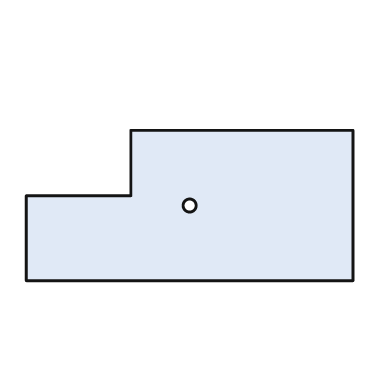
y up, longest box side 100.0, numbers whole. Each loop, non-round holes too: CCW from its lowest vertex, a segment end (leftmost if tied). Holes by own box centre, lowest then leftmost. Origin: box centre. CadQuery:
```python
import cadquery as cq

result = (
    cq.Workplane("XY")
    .moveTo(-50.0, -23.0)
    .lineTo(50.0, -23.0)
    .lineTo(50.0, 23.0)
    .lineTo(-18.0, 23.0)
    .lineTo(-18.0, 3.0)
    .lineTo(-50.0, 3.0)
    .close()
    .moveTo(0.0, 0.0)
    .circle(2.0)
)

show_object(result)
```